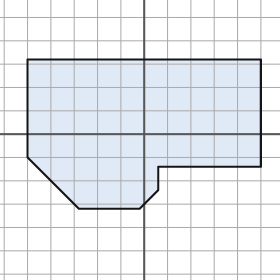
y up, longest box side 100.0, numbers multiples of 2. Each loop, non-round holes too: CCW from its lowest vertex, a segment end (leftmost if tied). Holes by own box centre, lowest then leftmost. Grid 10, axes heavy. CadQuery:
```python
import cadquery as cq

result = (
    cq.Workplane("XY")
    .moveTo(-28.0, -32.0)
    .lineTo(-2.0, -32.0)
    .lineTo(6.0, -24.0)
    .lineTo(6.0, -14.0)
    .lineTo(50.0, -14.0)
    .lineTo(50.0, 32.0)
    .lineTo(-50.0, 32.0)
    .lineTo(-50.0, -10.0)
    .close()
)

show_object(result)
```